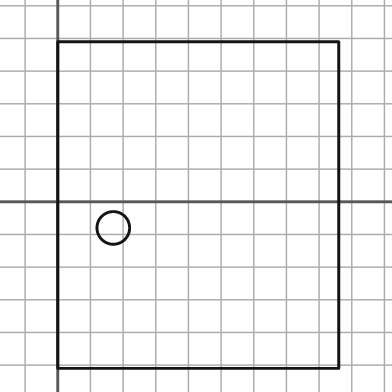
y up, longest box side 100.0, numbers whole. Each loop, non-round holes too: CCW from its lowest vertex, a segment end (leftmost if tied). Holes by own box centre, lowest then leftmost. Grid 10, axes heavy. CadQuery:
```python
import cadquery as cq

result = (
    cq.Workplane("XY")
    .moveTo(0.0, -51.0)
    .lineTo(86.0, -51.0)
    .lineTo(86.0, 49.0)
    .lineTo(0.0, 49.0)
    .close()
    .moveTo(17.0, -8.0)
    .circle(5.0)
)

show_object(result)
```